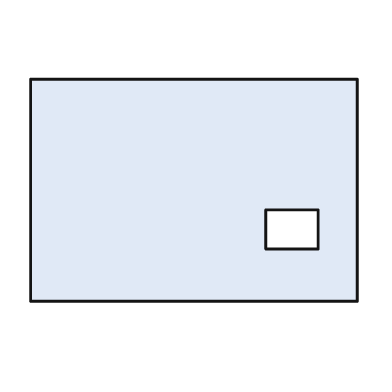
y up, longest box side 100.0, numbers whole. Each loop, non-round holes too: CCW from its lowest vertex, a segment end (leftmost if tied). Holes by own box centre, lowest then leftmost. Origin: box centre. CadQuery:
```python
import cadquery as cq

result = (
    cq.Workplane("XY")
    .moveTo(-50.0, -34.0)
    .lineTo(50.0, -34.0)
    .lineTo(50.0, 34.0)
    .lineTo(-50.0, 34.0)
    .close()
    .moveTo(22.0, -18.0)
    .lineTo(38.0, -18.0)
    .lineTo(38.0, -6.0)
    .lineTo(22.0, -6.0)
    .close()
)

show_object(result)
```